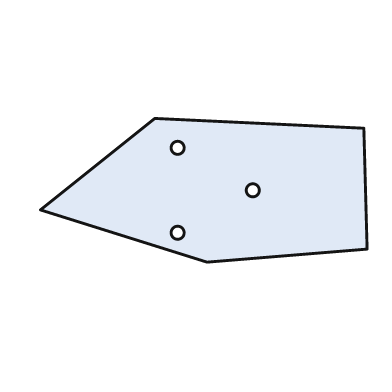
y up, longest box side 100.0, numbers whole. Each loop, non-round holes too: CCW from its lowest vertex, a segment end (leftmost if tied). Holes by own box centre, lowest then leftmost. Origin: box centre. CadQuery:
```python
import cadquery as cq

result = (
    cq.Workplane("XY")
    .moveTo(1.0, -22.0)
    .lineTo(50.0, -18.0)
    .lineTo(49.0, 19.0)
    .lineTo(-15.0, 22.0)
    .lineTo(-50.0, -6.0)
    .close()
    .moveTo(-8.0, -13.0)
    .circle(2.0)
    .moveTo(15.0, 0.0)
    .circle(2.0)
    .moveTo(-8.0, 13.0)
    .circle(2.0)
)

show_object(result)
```